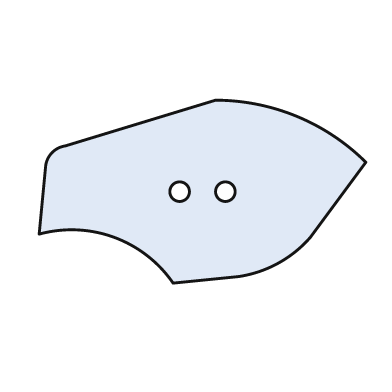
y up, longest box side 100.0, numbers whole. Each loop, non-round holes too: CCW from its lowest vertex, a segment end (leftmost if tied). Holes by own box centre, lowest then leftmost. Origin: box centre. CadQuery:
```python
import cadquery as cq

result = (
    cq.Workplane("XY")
    .moveTo(-9.0, -28.0)
    .lineTo(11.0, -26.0)
    .threePointArc((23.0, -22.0), (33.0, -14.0))
    .lineTo(50.0, 9.0)
    .threePointArc((29.0, 23.0), (4.0, 28.0))
    .lineTo(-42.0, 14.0)
    .threePointArc((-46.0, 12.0), (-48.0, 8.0))
    .lineTo(-50.0, -13.0)
    .threePointArc((-27.0, -14.0), (-9.0, -28.0))
    .close()
    .moveTo(-7.0, 0.0)
    .circle(3.0)
    .moveTo(7.0, 0.0)
    .circle(3.0)
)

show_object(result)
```